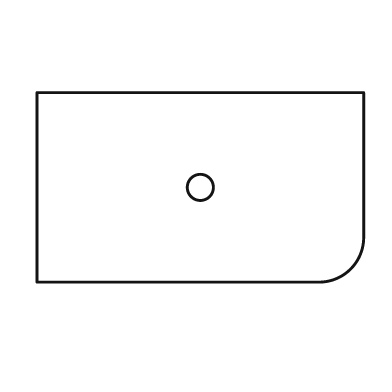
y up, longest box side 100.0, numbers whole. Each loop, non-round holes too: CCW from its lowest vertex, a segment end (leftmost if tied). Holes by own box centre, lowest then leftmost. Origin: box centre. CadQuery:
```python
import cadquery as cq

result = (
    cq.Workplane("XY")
    .moveTo(-50.0, -29.0)
    .lineTo(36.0, -29.0)
    .threePointArc((46.0, -25.0), (50.0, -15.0))
    .lineTo(50.0, 29.0)
    .lineTo(-50.0, 29.0)
    .close()
    .moveTo(0.0, 0.0)
    .circle(4.0)
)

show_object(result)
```